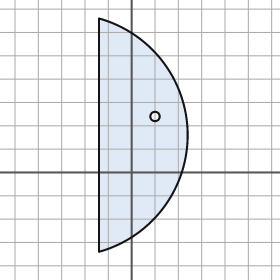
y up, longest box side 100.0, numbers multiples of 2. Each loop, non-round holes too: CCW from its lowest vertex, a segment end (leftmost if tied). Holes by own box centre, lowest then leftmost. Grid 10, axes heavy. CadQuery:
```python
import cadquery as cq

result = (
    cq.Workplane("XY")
    .moveTo(-14.0, -34.0)
    .threePointArc((24.0, 16.0), (-14.0, 66.0))
    .close()
    .moveTo(10.0, 24.0)
    .circle(2.0)
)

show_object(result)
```